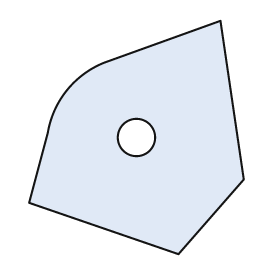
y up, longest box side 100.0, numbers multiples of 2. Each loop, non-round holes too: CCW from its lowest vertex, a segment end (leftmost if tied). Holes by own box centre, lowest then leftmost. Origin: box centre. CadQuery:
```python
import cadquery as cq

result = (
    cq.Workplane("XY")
    .moveTo(18.0, -50.0)
    .lineTo(46.0, -18.0)
    .lineTo(36.0, 50.0)
    .lineTo(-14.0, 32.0)
    .threePointArc((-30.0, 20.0), (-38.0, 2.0))
    .lineTo(-46.0, -28.0)
    .close()
    .moveTo(0.0, 0.0)
    .circle(8.0)
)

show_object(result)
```